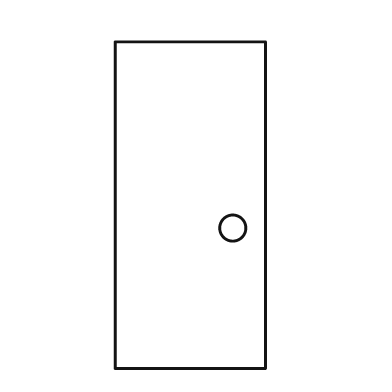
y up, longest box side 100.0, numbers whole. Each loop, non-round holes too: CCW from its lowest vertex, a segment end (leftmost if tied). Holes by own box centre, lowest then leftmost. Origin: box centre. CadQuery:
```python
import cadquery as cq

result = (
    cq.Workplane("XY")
    .moveTo(-23.0, -50.0)
    .lineTo(23.0, -50.0)
    .lineTo(23.0, 50.0)
    .lineTo(-23.0, 50.0)
    .close()
    .moveTo(13.0, -7.0)
    .circle(4.0)
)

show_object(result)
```